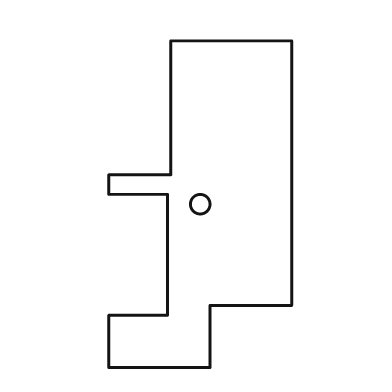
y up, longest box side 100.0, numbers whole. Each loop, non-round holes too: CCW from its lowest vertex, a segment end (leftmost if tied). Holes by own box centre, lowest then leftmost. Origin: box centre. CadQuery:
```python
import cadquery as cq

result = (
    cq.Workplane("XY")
    .moveTo(-28.0, -50.0)
    .lineTo(3.0, -50.0)
    .lineTo(3.0, -31.0)
    .lineTo(28.0, -31.0)
    .lineTo(28.0, 50.0)
    .lineTo(-9.0, 50.0)
    .lineTo(-9.0, 9.0)
    .lineTo(-28.0, 9.0)
    .lineTo(-28.0, 3.0)
    .lineTo(-10.0, 3.0)
    .lineTo(-10.0, -34.0)
    .lineTo(-28.0, -34.0)
    .close()
    .moveTo(0.0, 0.0)
    .circle(3.0)
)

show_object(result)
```